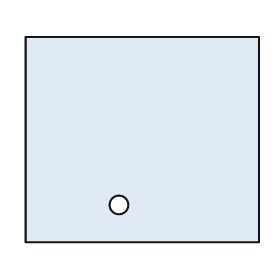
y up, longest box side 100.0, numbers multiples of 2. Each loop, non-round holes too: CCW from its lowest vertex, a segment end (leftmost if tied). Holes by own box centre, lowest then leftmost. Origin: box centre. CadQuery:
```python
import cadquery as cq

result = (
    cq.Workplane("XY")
    .moveTo(-50.0, -44.0)
    .lineTo(50.0, -44.0)
    .lineTo(50.0, 44.0)
    .lineTo(-50.0, 44.0)
    .close()
    .moveTo(-10.0, -28.0)
    .circle(4.0)
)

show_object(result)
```